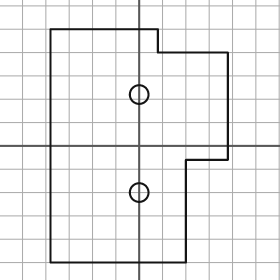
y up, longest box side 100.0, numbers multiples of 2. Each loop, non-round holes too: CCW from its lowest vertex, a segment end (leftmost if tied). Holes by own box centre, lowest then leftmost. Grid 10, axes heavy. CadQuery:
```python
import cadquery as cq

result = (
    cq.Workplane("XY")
    .moveTo(-38.0, -50.0)
    .lineTo(20.0, -50.0)
    .lineTo(20.0, -6.0)
    .lineTo(38.0, -6.0)
    .lineTo(38.0, 40.0)
    .lineTo(8.0, 40.0)
    .lineTo(8.0, 50.0)
    .lineTo(-38.0, 50.0)
    .close()
    .moveTo(0.0, -20.0)
    .circle(4.0)
    .moveTo(0.0, 22.0)
    .circle(4.0)
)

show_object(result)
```